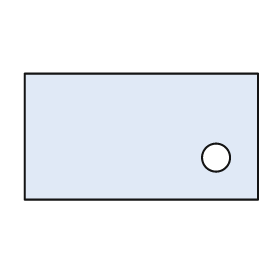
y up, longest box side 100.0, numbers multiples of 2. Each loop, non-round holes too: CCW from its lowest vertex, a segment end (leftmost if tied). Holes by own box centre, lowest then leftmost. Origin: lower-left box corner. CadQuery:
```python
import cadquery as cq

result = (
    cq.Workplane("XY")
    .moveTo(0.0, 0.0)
    .lineTo(100.0, 0.0)
    .lineTo(100.0, 54.0)
    .lineTo(0.0, 54.0)
    .close()
    .moveTo(82.0, 18.0)
    .circle(6.0)
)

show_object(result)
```